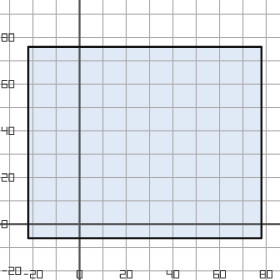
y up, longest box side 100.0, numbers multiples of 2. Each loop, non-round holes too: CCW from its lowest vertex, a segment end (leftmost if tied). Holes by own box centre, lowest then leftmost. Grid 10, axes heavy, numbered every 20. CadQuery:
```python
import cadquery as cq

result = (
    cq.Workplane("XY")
    .moveTo(-22.0, -6.0)
    .lineTo(78.0, -6.0)
    .lineTo(78.0, 76.0)
    .lineTo(-22.0, 76.0)
    .close()
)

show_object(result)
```